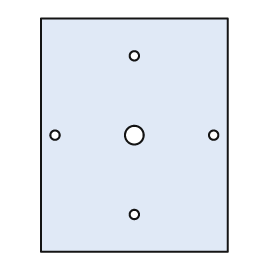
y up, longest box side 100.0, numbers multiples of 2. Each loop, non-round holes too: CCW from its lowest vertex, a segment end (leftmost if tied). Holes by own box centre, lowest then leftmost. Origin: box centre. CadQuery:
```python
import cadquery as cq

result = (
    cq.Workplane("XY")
    .moveTo(-40.0, -50.0)
    .lineTo(40.0, -50.0)
    .lineTo(40.0, 50.0)
    .lineTo(-40.0, 50.0)
    .close()
    .moveTo(0.0, -34.0)
    .circle(2.0)
    .moveTo(-34.0, 0.0)
    .circle(2.0)
    .moveTo(0.0, 0.0)
    .circle(4.0)
    .moveTo(34.0, 0.0)
    .circle(2.0)
    .moveTo(0.0, 34.0)
    .circle(2.0)
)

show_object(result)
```